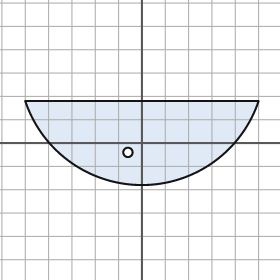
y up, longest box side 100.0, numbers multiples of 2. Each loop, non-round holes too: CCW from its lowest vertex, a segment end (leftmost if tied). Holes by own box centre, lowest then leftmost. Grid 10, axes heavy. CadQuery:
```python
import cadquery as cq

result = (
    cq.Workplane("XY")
    .moveTo(-50.0, 18.0)
    .threePointArc((0.0, -18.0), (50.0, 18.0))
    .close()
    .moveTo(-6.0, -4.0)
    .circle(2.0)
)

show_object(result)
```